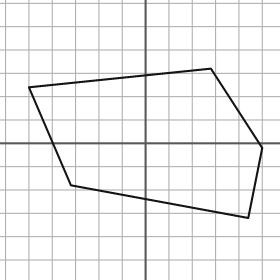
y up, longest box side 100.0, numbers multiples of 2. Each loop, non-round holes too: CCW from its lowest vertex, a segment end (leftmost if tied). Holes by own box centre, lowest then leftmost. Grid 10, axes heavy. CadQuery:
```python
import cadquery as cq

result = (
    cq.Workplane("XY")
    .moveTo(44.0, -32.0)
    .lineTo(50.0, -2.0)
    .lineTo(28.0, 32.0)
    .lineTo(-50.0, 24.0)
    .lineTo(-32.0, -18.0)
    .close()
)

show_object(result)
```